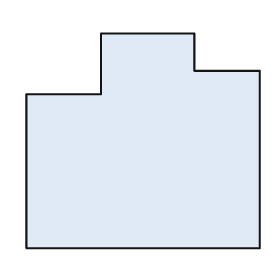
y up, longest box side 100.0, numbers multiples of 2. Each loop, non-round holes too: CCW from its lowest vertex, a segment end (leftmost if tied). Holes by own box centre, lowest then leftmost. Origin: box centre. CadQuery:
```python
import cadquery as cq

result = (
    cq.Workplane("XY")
    .moveTo(-50.0, -46.0)
    .lineTo(50.0, -46.0)
    .lineTo(50.0, 30.0)
    .lineTo(22.0, 30.0)
    .lineTo(22.0, 46.0)
    .lineTo(-18.0, 46.0)
    .lineTo(-18.0, 20.0)
    .lineTo(-50.0, 20.0)
    .close()
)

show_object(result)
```